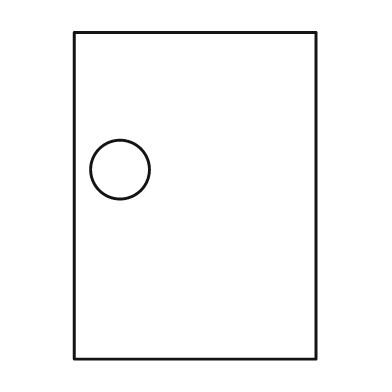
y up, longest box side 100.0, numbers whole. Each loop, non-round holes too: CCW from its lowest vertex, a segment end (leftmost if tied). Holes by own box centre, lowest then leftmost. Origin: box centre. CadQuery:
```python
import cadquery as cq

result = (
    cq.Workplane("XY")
    .moveTo(-37.0, -50.0)
    .lineTo(37.0, -50.0)
    .lineTo(37.0, 50.0)
    .lineTo(-37.0, 50.0)
    .close()
    .moveTo(-23.0, 8.0)
    .circle(9.0)
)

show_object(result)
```